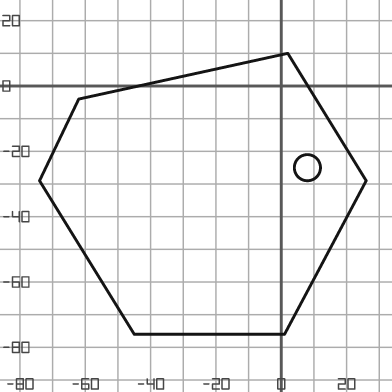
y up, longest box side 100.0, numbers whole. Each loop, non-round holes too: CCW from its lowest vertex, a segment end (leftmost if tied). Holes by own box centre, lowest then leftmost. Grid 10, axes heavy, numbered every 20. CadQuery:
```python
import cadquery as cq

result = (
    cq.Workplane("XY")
    .moveTo(-45.0, -76.0)
    .lineTo(1.0, -76.0)
    .lineTo(26.0, -29.0)
    .lineTo(2.0, 10.0)
    .lineTo(-62.0, -4.0)
    .lineTo(-74.0, -29.0)
    .close()
    .moveTo(8.0, -25.0)
    .circle(4.0)
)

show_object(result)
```